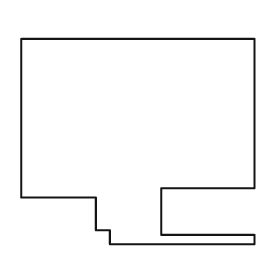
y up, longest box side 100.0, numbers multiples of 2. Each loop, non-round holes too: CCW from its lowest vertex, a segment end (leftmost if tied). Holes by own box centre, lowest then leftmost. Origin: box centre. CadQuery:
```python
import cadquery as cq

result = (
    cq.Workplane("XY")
    .moveTo(-12.0, -44.0)
    .lineTo(50.0, -44.0)
    .lineTo(50.0, -40.0)
    .lineTo(10.0, -40.0)
    .lineTo(10.0, -20.0)
    .lineTo(50.0, -20.0)
    .lineTo(50.0, 44.0)
    .lineTo(-50.0, 44.0)
    .lineTo(-50.0, -24.0)
    .lineTo(-18.0, -24.0)
    .lineTo(-18.0, -38.0)
    .lineTo(-12.0, -38.0)
    .close()
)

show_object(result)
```